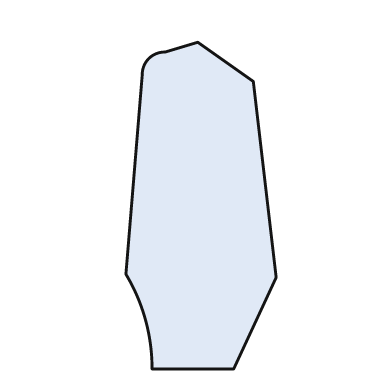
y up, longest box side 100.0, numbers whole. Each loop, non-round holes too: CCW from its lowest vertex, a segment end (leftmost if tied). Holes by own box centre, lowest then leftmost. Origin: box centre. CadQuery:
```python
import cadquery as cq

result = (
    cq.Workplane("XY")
    .moveTo(-15.0, -50.0)
    .lineTo(10.0, -50.0)
    .lineTo(23.0, -22.0)
    .lineTo(16.0, 38.0)
    .lineTo(-1.0, 50.0)
    .lineTo(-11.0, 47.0)
    .threePointArc((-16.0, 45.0), (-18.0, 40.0))
    .lineTo(-23.0, -21.0)
    .threePointArc((-17.0, -35.0), (-15.0, -50.0))
    .close()
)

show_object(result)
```